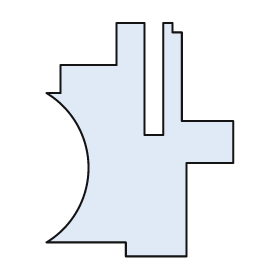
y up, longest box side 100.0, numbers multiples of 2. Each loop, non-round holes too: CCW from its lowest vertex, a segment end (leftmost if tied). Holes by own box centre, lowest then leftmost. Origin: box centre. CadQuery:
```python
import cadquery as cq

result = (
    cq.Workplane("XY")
    .moveTo(-6.0, -50.0)
    .lineTo(20.0, -50.0)
    .lineTo(20.0, -10.0)
    .lineTo(40.0, -10.0)
    .lineTo(40.0, 8.0)
    .lineTo(18.0, 8.0)
    .lineTo(18.0, 46.0)
    .lineTo(14.0, 46.0)
    .lineTo(14.0, 50.0)
    .lineTo(10.0, 50.0)
    .lineTo(10.0, 2.0)
    .lineTo(2.0, 2.0)
    .lineTo(2.0, 50.0)
    .lineTo(-10.0, 50.0)
    .lineTo(-10.0, 32.0)
    .lineTo(-34.0, 32.0)
    .lineTo(-34.0, 20.0)
    .lineTo(-40.0, 20.0)
    .threePointArc((-22.0, -12.0), (-40.0, -44.0))
    .lineTo(-6.0, -44.0)
    .close()
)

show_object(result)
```